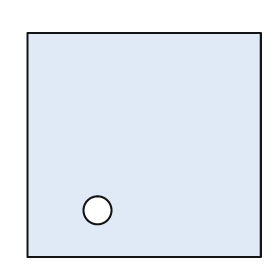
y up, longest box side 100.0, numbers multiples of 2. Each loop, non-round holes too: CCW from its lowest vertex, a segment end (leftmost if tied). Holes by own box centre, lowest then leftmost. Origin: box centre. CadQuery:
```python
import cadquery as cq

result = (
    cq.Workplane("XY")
    .moveTo(-50.0, -48.0)
    .lineTo(50.0, -48.0)
    .lineTo(50.0, 48.0)
    .lineTo(-50.0, 48.0)
    .close()
    .moveTo(-20.0, -28.0)
    .circle(6.0)
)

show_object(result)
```